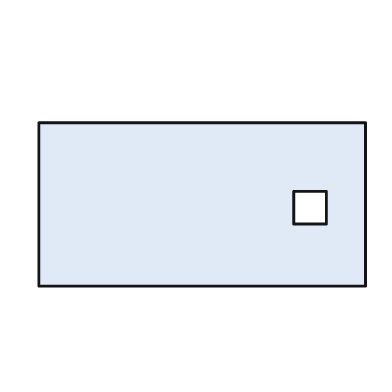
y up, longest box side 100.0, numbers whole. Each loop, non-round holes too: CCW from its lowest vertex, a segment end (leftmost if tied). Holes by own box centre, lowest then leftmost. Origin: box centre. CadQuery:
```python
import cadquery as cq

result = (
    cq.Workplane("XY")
    .moveTo(-50.0, -25.0)
    .lineTo(50.0, -25.0)
    .lineTo(50.0, 25.0)
    .lineTo(-50.0, 25.0)
    .close()
    .moveTo(28.0, -6.0)
    .lineTo(38.0, -6.0)
    .lineTo(38.0, 4.0)
    .lineTo(28.0, 4.0)
    .close()
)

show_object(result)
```